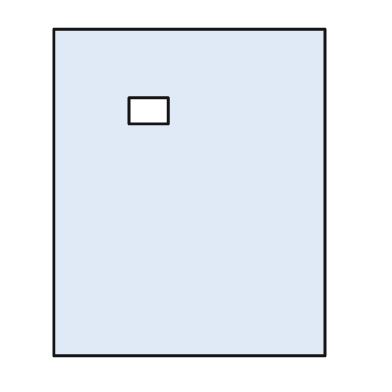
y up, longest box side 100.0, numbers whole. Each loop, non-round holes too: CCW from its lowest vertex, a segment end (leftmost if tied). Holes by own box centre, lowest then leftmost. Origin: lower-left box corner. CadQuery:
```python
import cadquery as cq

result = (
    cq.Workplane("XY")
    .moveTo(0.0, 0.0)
    .lineTo(83.0, 0.0)
    .lineTo(83.0, 100.0)
    .lineTo(0.0, 100.0)
    .close()
    .moveTo(23.0, 71.0)
    .lineTo(35.0, 71.0)
    .lineTo(35.0, 79.0)
    .lineTo(23.0, 79.0)
    .close()
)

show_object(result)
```